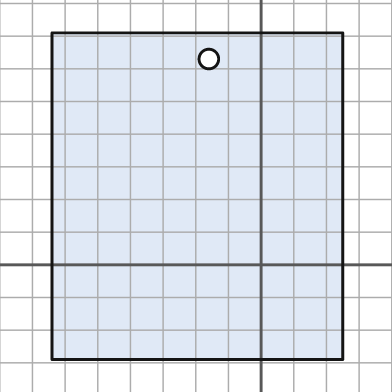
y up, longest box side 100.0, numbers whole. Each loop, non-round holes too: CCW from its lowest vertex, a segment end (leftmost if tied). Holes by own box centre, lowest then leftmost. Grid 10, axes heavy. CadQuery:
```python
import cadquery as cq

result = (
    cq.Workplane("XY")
    .moveTo(-64.0, -29.0)
    .lineTo(25.0, -29.0)
    .lineTo(25.0, 71.0)
    .lineTo(-64.0, 71.0)
    .close()
    .moveTo(-16.0, 63.0)
    .circle(3.0)
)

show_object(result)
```